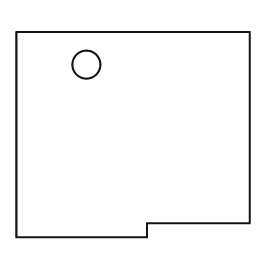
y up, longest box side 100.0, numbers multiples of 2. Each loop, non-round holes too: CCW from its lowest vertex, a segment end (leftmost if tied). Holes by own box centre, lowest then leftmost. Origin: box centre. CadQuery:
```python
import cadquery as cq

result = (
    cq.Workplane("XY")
    .moveTo(-50.0, -44.0)
    .lineTo(6.0, -44.0)
    .lineTo(6.0, -38.0)
    .lineTo(50.0, -38.0)
    .lineTo(50.0, 44.0)
    .lineTo(-50.0, 44.0)
    .close()
    .moveTo(-20.0, 30.0)
    .circle(6.0)
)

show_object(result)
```